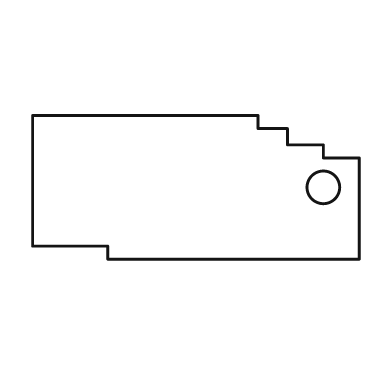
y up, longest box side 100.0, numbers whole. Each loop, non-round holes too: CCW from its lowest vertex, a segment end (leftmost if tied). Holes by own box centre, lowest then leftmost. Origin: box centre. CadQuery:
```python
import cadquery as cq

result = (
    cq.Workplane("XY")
    .moveTo(-27.0, -22.0)
    .lineTo(50.0, -22.0)
    .lineTo(50.0, 9.0)
    .lineTo(39.0, 9.0)
    .lineTo(39.0, 13.0)
    .lineTo(28.0, 13.0)
    .lineTo(28.0, 18.0)
    .lineTo(19.0, 18.0)
    .lineTo(19.0, 22.0)
    .lineTo(-50.0, 22.0)
    .lineTo(-50.0, -18.0)
    .lineTo(-27.0, -18.0)
    .close()
    .moveTo(39.0, 0.0)
    .circle(5.0)
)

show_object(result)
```